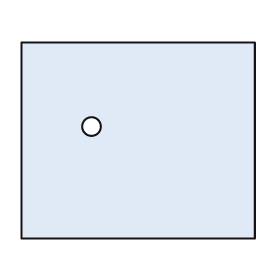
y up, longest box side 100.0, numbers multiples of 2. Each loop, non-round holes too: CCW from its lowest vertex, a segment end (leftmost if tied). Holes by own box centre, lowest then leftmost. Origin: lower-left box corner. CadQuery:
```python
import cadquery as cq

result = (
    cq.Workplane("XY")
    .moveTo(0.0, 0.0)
    .lineTo(100.0, 0.0)
    .lineTo(100.0, 84.0)
    .lineTo(0.0, 84.0)
    .close()
    .moveTo(30.0, 48.0)
    .circle(4.0)
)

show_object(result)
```